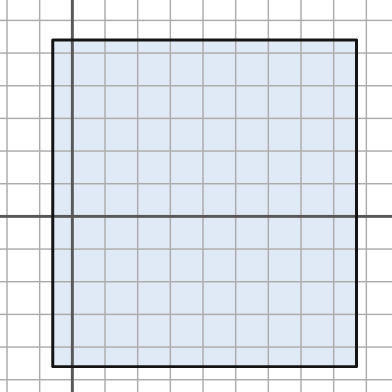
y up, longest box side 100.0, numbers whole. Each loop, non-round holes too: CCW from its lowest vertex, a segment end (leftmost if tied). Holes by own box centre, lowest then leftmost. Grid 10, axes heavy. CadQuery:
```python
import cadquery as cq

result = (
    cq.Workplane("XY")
    .moveTo(-6.0, -46.0)
    .lineTo(87.0, -46.0)
    .lineTo(87.0, 54.0)
    .lineTo(-6.0, 54.0)
    .close()
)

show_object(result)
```